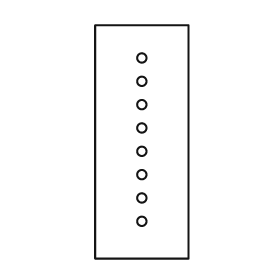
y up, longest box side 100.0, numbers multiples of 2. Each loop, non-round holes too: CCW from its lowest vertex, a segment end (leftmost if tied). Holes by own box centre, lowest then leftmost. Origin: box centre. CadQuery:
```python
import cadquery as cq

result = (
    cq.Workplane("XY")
    .moveTo(-20.0, -50.0)
    .lineTo(20.0, -50.0)
    .lineTo(20.0, 50.0)
    .lineTo(-20.0, 50.0)
    .close()
    .moveTo(0.0, -34.0)
    .circle(2.0)
    .moveTo(0.0, -24.0)
    .circle(2.0)
    .moveTo(0.0, -14.0)
    .circle(2.0)
    .moveTo(0.0, -4.0)
    .circle(2.0)
    .moveTo(0.0, 6.0)
    .circle(2.0)
    .moveTo(0.0, 16.0)
    .circle(2.0)
    .moveTo(0.0, 26.0)
    .circle(2.0)
    .moveTo(0.0, 36.0)
    .circle(2.0)
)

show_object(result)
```